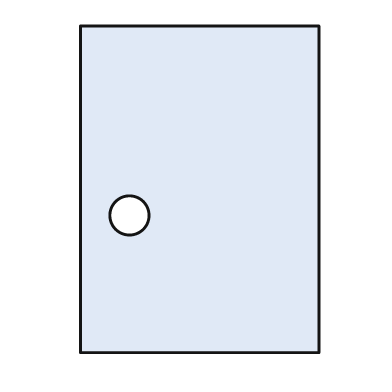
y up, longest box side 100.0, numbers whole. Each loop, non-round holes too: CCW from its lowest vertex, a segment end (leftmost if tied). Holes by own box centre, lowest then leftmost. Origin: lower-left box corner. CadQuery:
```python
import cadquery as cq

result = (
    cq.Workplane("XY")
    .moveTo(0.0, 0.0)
    .lineTo(73.0, 0.0)
    .lineTo(73.0, 100.0)
    .lineTo(0.0, 100.0)
    .close()
    .moveTo(15.0, 42.0)
    .circle(6.0)
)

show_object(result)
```